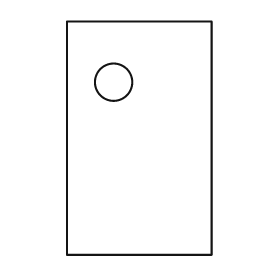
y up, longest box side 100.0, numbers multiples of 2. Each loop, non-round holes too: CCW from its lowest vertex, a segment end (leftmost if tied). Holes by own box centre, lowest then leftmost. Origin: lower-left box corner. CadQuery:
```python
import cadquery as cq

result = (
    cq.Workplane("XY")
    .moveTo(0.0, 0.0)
    .lineTo(62.0, 0.0)
    .lineTo(62.0, 100.0)
    .lineTo(0.0, 100.0)
    .close()
    .moveTo(20.0, 74.0)
    .circle(8.0)
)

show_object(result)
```